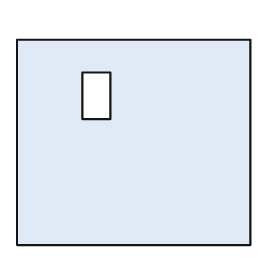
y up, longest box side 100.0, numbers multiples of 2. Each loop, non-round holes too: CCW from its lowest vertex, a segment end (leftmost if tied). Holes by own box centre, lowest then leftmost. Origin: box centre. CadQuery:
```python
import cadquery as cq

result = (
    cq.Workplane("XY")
    .moveTo(-50.0, -44.0)
    .lineTo(50.0, -44.0)
    .lineTo(50.0, 44.0)
    .lineTo(-50.0, 44.0)
    .close()
    .moveTo(-22.0, 10.0)
    .lineTo(-10.0, 10.0)
    .lineTo(-10.0, 30.0)
    .lineTo(-22.0, 30.0)
    .close()
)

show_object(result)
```